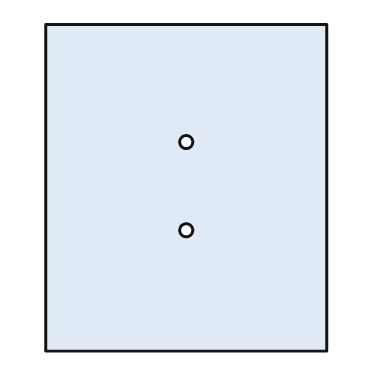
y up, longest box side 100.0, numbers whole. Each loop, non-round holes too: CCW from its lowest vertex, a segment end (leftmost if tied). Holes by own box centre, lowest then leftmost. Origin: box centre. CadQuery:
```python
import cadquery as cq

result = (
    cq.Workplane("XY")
    .moveTo(-43.0, -50.0)
    .lineTo(43.0, -50.0)
    .lineTo(43.0, 50.0)
    .lineTo(-43.0, 50.0)
    .close()
    .moveTo(0.0, -13.0)
    .circle(2.0)
    .moveTo(0.0, 14.0)
    .circle(2.0)
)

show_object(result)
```